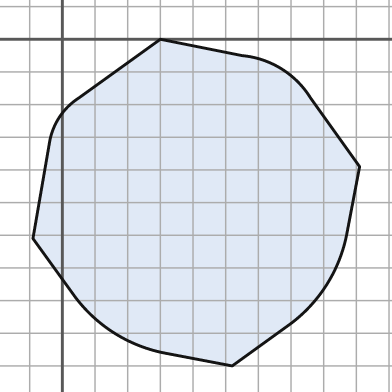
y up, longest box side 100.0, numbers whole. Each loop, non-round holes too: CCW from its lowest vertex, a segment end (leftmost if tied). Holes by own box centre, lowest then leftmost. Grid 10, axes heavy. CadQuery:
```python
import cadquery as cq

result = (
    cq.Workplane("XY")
    .moveTo(52.0, -100.0)
    .lineTo(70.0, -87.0)
    .threePointArc((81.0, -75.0), (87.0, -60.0))
    .lineTo(91.0, -39.0)
    .lineTo(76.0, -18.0)
    .threePointArc((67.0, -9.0), (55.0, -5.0))
    .lineTo(30.0, 0.0)
    .lineTo(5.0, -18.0)
    .threePointArc((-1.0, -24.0), (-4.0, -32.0))
    .lineTo(-9.0, -61.0)
    .lineTo(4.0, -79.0)
    .threePointArc((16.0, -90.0), (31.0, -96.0))
    .close()
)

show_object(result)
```